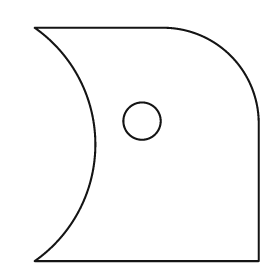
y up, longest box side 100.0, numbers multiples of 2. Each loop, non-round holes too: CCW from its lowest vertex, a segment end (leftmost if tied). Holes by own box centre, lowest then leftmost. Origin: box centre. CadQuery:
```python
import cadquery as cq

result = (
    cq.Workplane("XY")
    .moveTo(-48.0, -50.0)
    .lineTo(48.0, -50.0)
    .lineTo(48.0, 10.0)
    .threePointArc((36.0, 38.0), (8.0, 50.0))
    .lineTo(-48.0, 50.0)
    .threePointArc((-22.0, 0.0), (-48.0, -50.0))
    .close()
    .moveTo(-2.0, 10.0)
    .circle(8.0)
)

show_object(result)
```